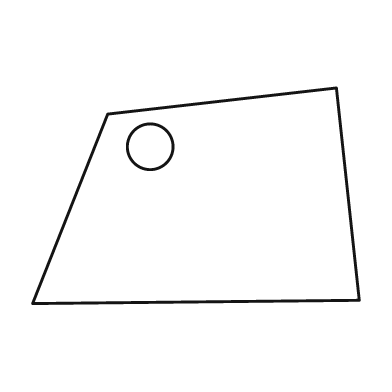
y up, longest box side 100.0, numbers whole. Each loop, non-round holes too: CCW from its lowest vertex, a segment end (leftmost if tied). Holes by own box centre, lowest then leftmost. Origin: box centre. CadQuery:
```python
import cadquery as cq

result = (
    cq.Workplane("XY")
    .moveTo(-50.0, -33.0)
    .lineTo(50.0, -32.0)
    .lineTo(43.0, 33.0)
    .lineTo(-27.0, 25.0)
    .close()
    .moveTo(-14.0, 15.0)
    .circle(7.0)
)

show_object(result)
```